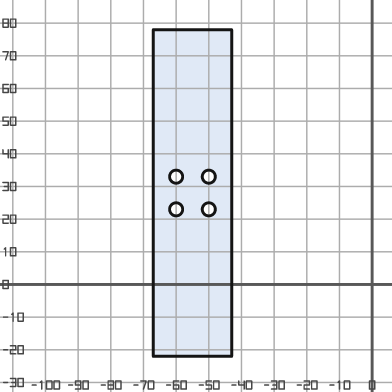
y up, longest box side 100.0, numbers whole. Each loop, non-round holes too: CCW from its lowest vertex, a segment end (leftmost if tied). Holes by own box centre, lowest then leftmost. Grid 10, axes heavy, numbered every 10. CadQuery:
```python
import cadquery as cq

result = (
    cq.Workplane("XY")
    .moveTo(-67.0, -22.0)
    .lineTo(-43.0, -22.0)
    .lineTo(-43.0, 78.0)
    .lineTo(-67.0, 78.0)
    .close()
    .moveTo(-60.0, 23.0)
    .circle(2.0)
    .moveTo(-50.0, 23.0)
    .circle(2.0)
    .moveTo(-60.0, 33.0)
    .circle(2.0)
    .moveTo(-50.0, 33.0)
    .circle(2.0)
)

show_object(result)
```